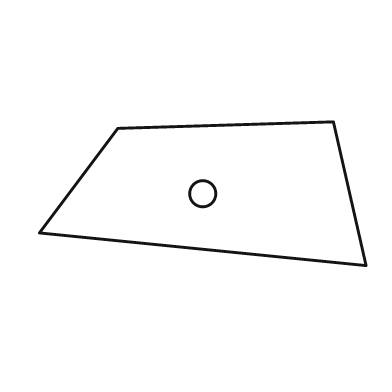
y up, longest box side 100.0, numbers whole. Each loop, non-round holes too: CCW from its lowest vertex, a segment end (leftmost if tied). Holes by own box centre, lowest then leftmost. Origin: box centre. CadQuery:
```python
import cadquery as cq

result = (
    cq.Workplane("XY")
    .moveTo(50.0, -22.0)
    .lineTo(40.0, 22.0)
    .lineTo(-26.0, 20.0)
    .lineTo(-50.0, -12.0)
    .close()
    .moveTo(0.0, 0.0)
    .circle(4.0)
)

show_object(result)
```